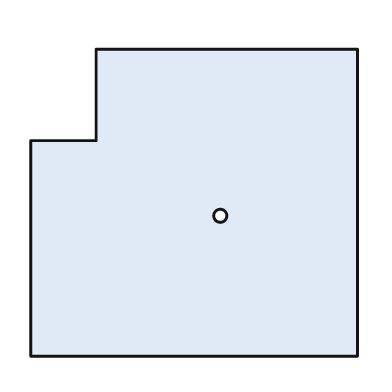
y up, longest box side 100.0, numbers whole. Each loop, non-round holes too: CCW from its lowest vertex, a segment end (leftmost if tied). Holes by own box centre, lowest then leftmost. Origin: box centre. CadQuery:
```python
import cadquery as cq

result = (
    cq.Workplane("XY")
    .moveTo(-50.0, -47.0)
    .lineTo(50.0, -47.0)
    .lineTo(50.0, 47.0)
    .lineTo(-30.0, 47.0)
    .lineTo(-30.0, 19.0)
    .lineTo(-50.0, 19.0)
    .close()
    .moveTo(8.0, -4.0)
    .circle(2.0)
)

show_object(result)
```